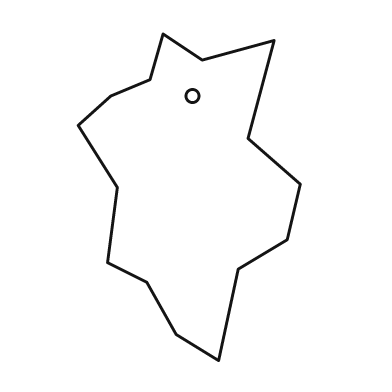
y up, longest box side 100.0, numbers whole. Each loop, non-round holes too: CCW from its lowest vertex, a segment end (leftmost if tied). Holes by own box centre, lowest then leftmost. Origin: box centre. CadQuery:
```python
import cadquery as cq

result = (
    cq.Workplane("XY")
    .moveTo(9.0, -50.0)
    .lineTo(15.0, -22.0)
    .lineTo(30.0, -13.0)
    .lineTo(34.0, 4.0)
    .lineTo(18.0, 18.0)
    .lineTo(26.0, 48.0)
    .lineTo(4.0, 42.0)
    .lineTo(-8.0, 50.0)
    .lineTo(-12.0, 36.0)
    .lineTo(-24.0, 31.0)
    .lineTo(-34.0, 22.0)
    .lineTo(-22.0, 3.0)
    .lineTo(-25.0, -20.0)
    .lineTo(-13.0, -26.0)
    .lineTo(-4.0, -42.0)
    .close()
    .moveTo(1.0, 31.0)
    .circle(2.0)
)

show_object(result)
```